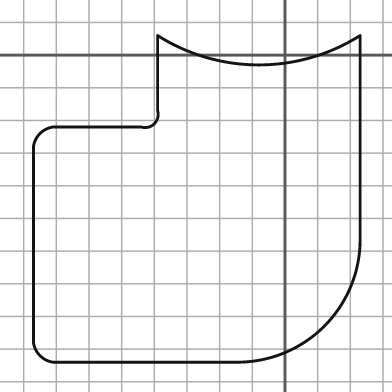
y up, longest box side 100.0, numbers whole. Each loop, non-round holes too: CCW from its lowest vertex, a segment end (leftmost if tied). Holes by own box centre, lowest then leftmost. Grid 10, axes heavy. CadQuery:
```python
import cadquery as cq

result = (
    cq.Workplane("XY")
    .moveTo(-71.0, -94.0)
    .lineTo(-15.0, -94.0)
    .threePointArc((12.0, -83.0), (23.0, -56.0))
    .lineTo(23.0, 6.0)
    .threePointArc((-8.0, -3.0), (-39.0, 6.0))
    .lineTo(-39.0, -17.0)
    .threePointArc((-40.0, -21.0), (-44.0, -22.0))
    .lineTo(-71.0, -22.0)
    .threePointArc((-75.0, -24.0), (-77.0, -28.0))
    .lineTo(-77.0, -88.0)
    .threePointArc((-75.0, -92.0), (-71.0, -94.0))
    .close()
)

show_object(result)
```